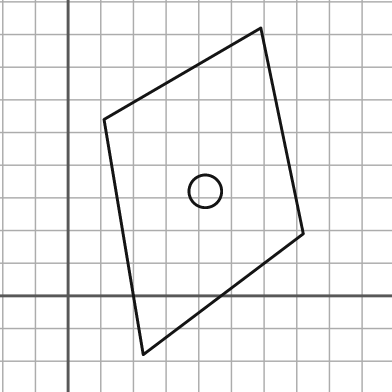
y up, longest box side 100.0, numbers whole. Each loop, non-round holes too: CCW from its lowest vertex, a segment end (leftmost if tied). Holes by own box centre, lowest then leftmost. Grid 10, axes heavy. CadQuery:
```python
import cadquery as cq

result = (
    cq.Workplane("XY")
    .moveTo(23.0, -18.0)
    .lineTo(72.0, 19.0)
    .lineTo(59.0, 82.0)
    .lineTo(11.0, 54.0)
    .close()
    .moveTo(42.0, 32.0)
    .circle(5.0)
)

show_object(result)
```